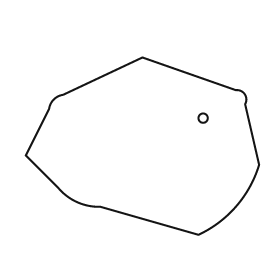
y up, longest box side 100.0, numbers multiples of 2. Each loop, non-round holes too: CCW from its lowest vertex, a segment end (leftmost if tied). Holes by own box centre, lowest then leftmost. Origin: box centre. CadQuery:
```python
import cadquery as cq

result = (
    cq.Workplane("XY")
    .moveTo(24.0, -38.0)
    .threePointArc((40.0, -26.0), (50.0, -8.0))
    .lineTo(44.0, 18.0)
    .threePointArc((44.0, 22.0), (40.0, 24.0))
    .lineTo(0.0, 38.0)
    .lineTo(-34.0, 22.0)
    .threePointArc((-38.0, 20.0), (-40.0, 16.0))
    .lineTo(-50.0, -4.0)
    .lineTo(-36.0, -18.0)
    .threePointArc((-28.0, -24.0), (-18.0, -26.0))
    .close()
    .moveTo(26.0, 12.0)
    .circle(2.0)
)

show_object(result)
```